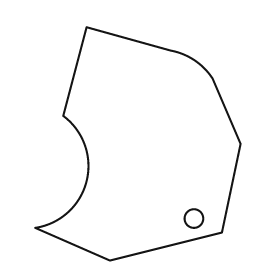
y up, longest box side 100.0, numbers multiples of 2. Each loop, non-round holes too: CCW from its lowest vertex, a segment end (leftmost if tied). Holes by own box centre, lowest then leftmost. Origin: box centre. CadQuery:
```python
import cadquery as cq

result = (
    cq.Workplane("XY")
    .moveTo(-12.0, -50.0)
    .lineTo(36.0, -38.0)
    .lineTo(44.0, 0.0)
    .lineTo(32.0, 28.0)
    .threePointArc((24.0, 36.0), (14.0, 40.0))
    .lineTo(-22.0, 50.0)
    .lineTo(-32.0, 12.0)
    .threePointArc((-22.0, -16.0), (-44.0, -36.0))
    .close()
    .moveTo(24.0, -32.0)
    .circle(4.0)
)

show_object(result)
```